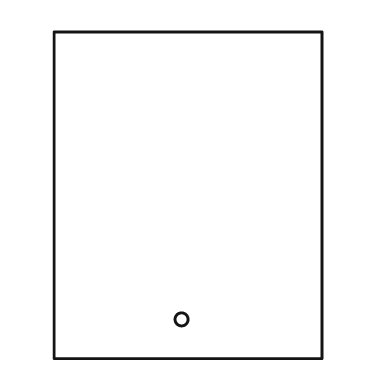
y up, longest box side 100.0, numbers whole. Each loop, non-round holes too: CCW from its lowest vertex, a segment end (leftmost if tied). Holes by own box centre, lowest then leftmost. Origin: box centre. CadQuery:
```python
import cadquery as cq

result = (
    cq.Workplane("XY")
    .moveTo(-41.0, -50.0)
    .lineTo(41.0, -50.0)
    .lineTo(41.0, 50.0)
    .lineTo(-41.0, 50.0)
    .close()
    .moveTo(-2.0, -38.0)
    .circle(2.0)
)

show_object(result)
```